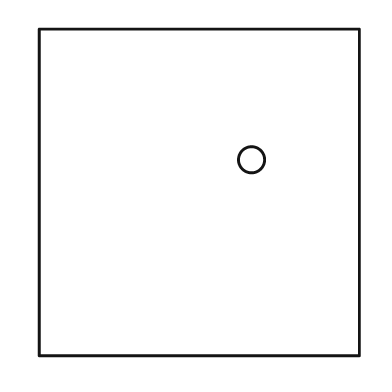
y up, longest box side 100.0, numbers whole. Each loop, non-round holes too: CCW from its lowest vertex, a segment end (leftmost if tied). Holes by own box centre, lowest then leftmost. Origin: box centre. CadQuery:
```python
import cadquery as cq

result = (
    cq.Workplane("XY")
    .moveTo(-49.0, -50.0)
    .lineTo(49.0, -50.0)
    .lineTo(49.0, 50.0)
    .lineTo(-49.0, 50.0)
    .close()
    .moveTo(16.0, 10.0)
    .circle(4.0)
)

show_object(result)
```